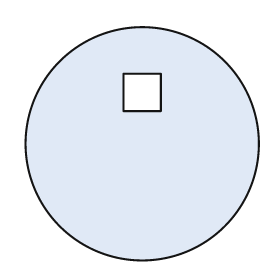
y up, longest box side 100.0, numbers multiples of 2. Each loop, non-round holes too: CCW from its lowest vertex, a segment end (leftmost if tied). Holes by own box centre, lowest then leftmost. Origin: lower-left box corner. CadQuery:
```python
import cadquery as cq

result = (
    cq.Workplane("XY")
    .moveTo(50.0, 50.0)
    .circle(50.0)
    .moveTo(42.0, 64.0)
    .lineTo(58.0, 64.0)
    .lineTo(58.0, 80.0)
    .lineTo(42.0, 80.0)
    .close()
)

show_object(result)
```